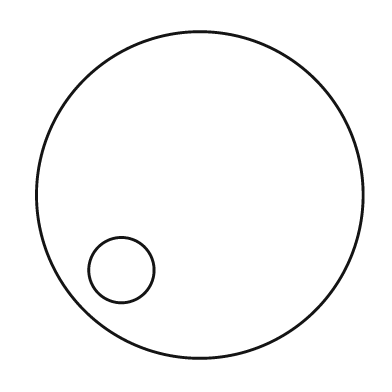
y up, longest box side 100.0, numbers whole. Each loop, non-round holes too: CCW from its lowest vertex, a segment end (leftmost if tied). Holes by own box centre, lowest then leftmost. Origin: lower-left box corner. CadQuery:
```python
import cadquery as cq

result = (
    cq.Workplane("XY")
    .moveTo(50.0, 50.0)
    .circle(50.0)
    .moveTo(26.0, 27.0)
    .circle(10.0)
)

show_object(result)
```